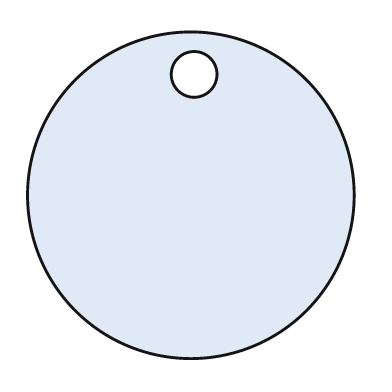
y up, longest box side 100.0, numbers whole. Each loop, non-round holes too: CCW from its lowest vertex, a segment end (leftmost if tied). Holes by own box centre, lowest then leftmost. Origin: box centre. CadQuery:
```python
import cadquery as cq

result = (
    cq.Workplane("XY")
    .moveTo(0.0, 0.0)
    .circle(50.0)
    .moveTo(1.0, 37.0)
    .circle(7.0)
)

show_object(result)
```